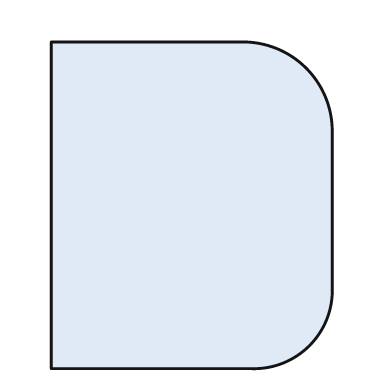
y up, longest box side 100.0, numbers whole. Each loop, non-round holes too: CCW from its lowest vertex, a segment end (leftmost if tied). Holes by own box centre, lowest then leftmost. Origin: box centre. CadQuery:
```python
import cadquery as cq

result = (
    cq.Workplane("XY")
    .moveTo(-43.0, -50.0)
    .lineTo(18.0, -50.0)
    .threePointArc((36.0, -43.0), (43.0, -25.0))
    .lineTo(43.0, 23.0)
    .threePointArc((35.0, 42.0), (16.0, 50.0))
    .lineTo(-43.0, 50.0)
    .close()
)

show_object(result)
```